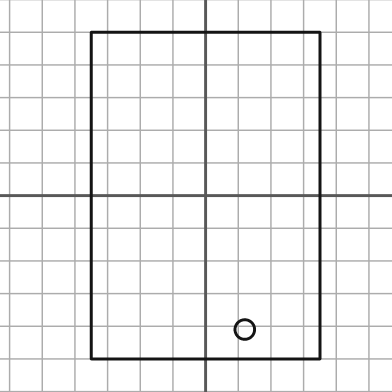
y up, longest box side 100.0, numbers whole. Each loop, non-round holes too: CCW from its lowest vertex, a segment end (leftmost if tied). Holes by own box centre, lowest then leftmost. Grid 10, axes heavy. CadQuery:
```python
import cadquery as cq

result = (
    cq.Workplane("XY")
    .moveTo(-35.0, -50.0)
    .lineTo(35.0, -50.0)
    .lineTo(35.0, 50.0)
    .lineTo(-35.0, 50.0)
    .close()
    .moveTo(12.0, -41.0)
    .circle(3.0)
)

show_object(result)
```